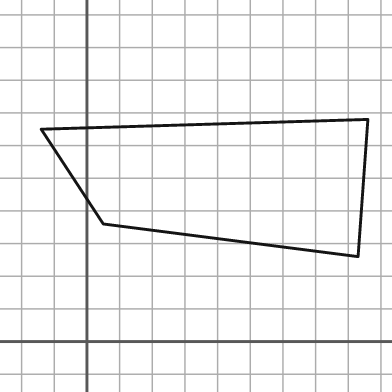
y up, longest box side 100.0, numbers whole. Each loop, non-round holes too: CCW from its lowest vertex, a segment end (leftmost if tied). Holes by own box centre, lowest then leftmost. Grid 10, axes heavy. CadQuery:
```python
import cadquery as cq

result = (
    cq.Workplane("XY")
    .moveTo(83.0, 26.0)
    .lineTo(86.0, 68.0)
    .lineTo(-14.0, 65.0)
    .lineTo(5.0, 36.0)
    .close()
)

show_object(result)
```